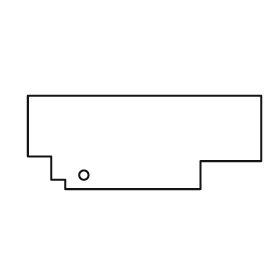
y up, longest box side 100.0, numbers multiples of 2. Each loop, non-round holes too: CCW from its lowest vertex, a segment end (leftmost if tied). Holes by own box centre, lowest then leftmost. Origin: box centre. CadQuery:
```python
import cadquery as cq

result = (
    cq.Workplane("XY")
    .moveTo(-34.0, -20.0)
    .lineTo(24.0, -20.0)
    .lineTo(24.0, -8.0)
    .lineTo(50.0, -8.0)
    .lineTo(50.0, 20.0)
    .lineTo(-50.0, 20.0)
    .lineTo(-50.0, -6.0)
    .lineTo(-40.0, -6.0)
    .lineTo(-40.0, -16.0)
    .lineTo(-34.0, -16.0)
    .close()
    .moveTo(-26.0, -14.0)
    .circle(2.0)
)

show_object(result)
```